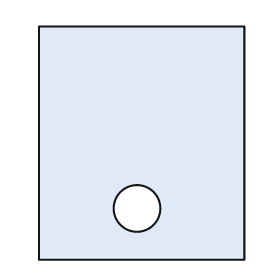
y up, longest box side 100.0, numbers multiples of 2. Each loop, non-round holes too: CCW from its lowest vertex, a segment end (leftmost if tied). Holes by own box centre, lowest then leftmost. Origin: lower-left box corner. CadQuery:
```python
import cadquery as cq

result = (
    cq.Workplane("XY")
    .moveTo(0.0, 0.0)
    .lineTo(88.0, 0.0)
    .lineTo(88.0, 100.0)
    .lineTo(0.0, 100.0)
    .close()
    .moveTo(42.0, 22.0)
    .circle(10.0)
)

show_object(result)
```